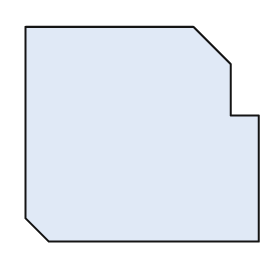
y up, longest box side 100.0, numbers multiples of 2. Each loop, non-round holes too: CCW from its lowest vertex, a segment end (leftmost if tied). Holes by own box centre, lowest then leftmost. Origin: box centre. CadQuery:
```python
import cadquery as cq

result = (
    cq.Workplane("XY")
    .moveTo(-40.0, -46.0)
    .lineTo(50.0, -46.0)
    .lineTo(50.0, 8.0)
    .lineTo(38.0, 8.0)
    .lineTo(38.0, 30.0)
    .lineTo(22.0, 46.0)
    .lineTo(-50.0, 46.0)
    .lineTo(-50.0, -36.0)
    .close()
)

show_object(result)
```